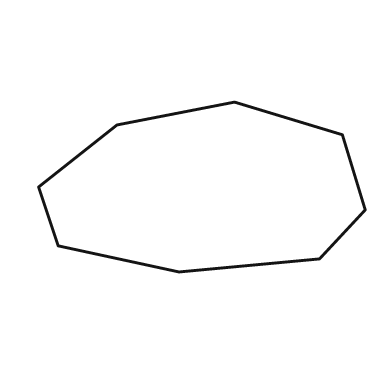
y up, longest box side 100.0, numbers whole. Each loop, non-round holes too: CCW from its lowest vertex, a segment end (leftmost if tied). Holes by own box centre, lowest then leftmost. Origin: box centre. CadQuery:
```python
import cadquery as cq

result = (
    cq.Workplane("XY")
    .moveTo(-7.0, -26.0)
    .lineTo(36.0, -22.0)
    .lineTo(50.0, -7.0)
    .lineTo(43.0, 16.0)
    .lineTo(10.0, 26.0)
    .lineTo(-26.0, 19.0)
    .lineTo(-50.0, 0.0)
    .lineTo(-44.0, -18.0)
    .close()
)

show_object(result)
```